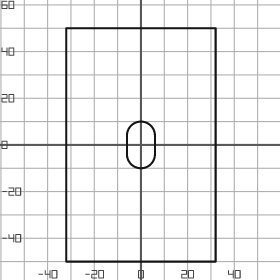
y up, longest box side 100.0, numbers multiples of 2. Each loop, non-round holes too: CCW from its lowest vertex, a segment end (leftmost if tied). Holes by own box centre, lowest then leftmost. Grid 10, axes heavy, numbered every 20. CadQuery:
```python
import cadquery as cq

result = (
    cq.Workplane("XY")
    .moveTo(-32.0, -50.0)
    .lineTo(32.0, -50.0)
    .lineTo(32.0, 50.0)
    .lineTo(-32.0, 50.0)
    .close()
    .moveTo(-6.0, -4.0)
    .threePointArc((0.0, -10.0), (6.0, -4.0))
    .lineTo(6.0, 4.0)
    .threePointArc((0.0, 10.0), (-6.0, 4.0))
    .close()
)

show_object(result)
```